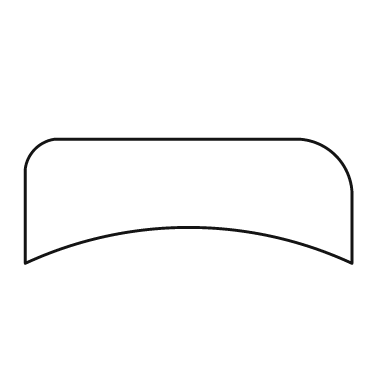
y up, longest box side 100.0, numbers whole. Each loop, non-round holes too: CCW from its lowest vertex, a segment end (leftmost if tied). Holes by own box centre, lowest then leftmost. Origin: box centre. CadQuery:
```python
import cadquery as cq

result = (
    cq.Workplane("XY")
    .moveTo(-50.0, -19.0)
    .threePointArc((0.0, -8.0), (50.0, -19.0))
    .lineTo(50.0, 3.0)
    .threePointArc((45.0, 14.0), (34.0, 19.0))
    .lineTo(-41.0, 19.0)
    .threePointArc((-47.0, 16.0), (-50.0, 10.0))
    .close()
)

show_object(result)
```